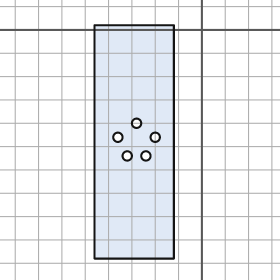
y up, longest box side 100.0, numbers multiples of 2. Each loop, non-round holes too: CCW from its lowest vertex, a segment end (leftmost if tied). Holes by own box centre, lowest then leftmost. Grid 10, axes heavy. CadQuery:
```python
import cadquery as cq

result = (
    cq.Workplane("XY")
    .moveTo(-46.0, -98.0)
    .lineTo(-12.0, -98.0)
    .lineTo(-12.0, 2.0)
    .lineTo(-46.0, 2.0)
    .close()
    .moveTo(-32.0, -54.0)
    .circle(2.0)
    .moveTo(-24.0, -54.0)
    .circle(2.0)
    .moveTo(-36.0, -46.0)
    .circle(2.0)
    .moveTo(-20.0, -46.0)
    .circle(2.0)
    .moveTo(-28.0, -40.0)
    .circle(2.0)
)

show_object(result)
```